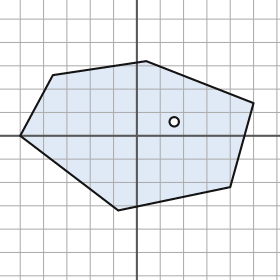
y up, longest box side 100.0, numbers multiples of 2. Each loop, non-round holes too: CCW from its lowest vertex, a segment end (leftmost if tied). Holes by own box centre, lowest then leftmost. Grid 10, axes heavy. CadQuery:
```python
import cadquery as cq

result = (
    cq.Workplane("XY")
    .moveTo(-8.0, -32.0)
    .lineTo(40.0, -22.0)
    .lineTo(50.0, 14.0)
    .lineTo(4.0, 32.0)
    .lineTo(-36.0, 26.0)
    .lineTo(-50.0, 0.0)
    .close()
    .moveTo(16.0, 6.0)
    .circle(2.0)
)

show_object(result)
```